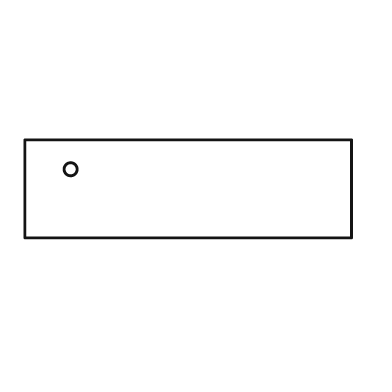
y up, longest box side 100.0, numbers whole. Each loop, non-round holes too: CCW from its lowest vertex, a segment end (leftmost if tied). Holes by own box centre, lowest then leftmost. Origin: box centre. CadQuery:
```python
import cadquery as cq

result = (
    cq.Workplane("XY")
    .moveTo(-50.0, -15.0)
    .lineTo(50.0, -15.0)
    .lineTo(50.0, 15.0)
    .lineTo(-50.0, 15.0)
    .close()
    .moveTo(-36.0, 6.0)
    .circle(2.0)
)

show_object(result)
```